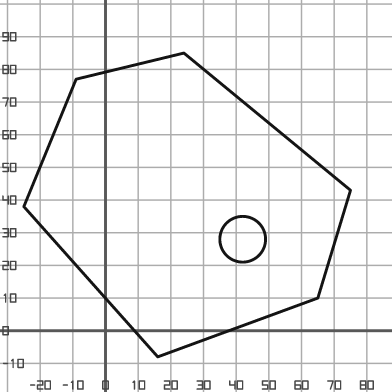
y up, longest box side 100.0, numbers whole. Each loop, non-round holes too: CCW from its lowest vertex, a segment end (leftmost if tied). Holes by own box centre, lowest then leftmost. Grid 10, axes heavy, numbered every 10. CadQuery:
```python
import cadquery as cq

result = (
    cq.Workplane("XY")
    .moveTo(16.0, -8.0)
    .lineTo(65.0, 10.0)
    .lineTo(75.0, 43.0)
    .lineTo(24.0, 85.0)
    .lineTo(-9.0, 77.0)
    .lineTo(-25.0, 38.0)
    .close()
    .moveTo(42.0, 28.0)
    .circle(7.0)
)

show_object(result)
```